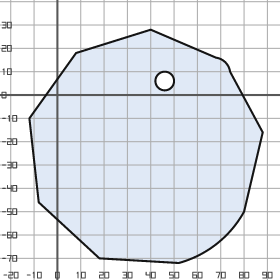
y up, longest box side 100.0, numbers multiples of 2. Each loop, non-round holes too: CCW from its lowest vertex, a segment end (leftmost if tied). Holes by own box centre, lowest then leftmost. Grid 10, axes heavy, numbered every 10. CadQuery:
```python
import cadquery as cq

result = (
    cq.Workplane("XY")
    .moveTo(52.0, -72.0)
    .threePointArc((68.0, -64.0), (80.0, -50.0))
    .lineTo(88.0, -16.0)
    .lineTo(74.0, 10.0)
    .threePointArc((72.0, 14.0), (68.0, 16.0))
    .lineTo(40.0, 28.0)
    .lineTo(8.0, 18.0)
    .lineTo(-12.0, -10.0)
    .lineTo(-8.0, -46.0)
    .lineTo(18.0, -70.0)
    .close()
    .moveTo(46.0, 6.0)
    .circle(4.0)
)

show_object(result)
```